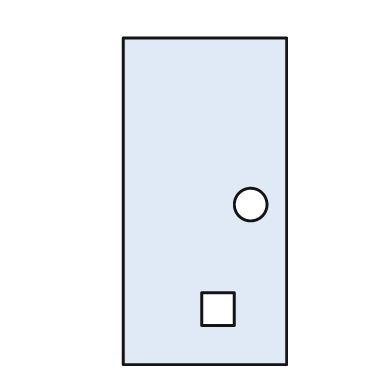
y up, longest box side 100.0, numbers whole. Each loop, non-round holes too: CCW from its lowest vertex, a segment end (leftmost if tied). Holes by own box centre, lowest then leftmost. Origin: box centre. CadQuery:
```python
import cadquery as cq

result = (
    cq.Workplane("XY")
    .moveTo(-25.0, -50.0)
    .lineTo(25.0, -50.0)
    .lineTo(25.0, 50.0)
    .lineTo(-25.0, 50.0)
    .close()
    .moveTo(-1.0, -38.0)
    .lineTo(9.0, -38.0)
    .lineTo(9.0, -28.0)
    .lineTo(-1.0, -28.0)
    .close()
    .moveTo(14.0, -1.0)
    .circle(5.0)
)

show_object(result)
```